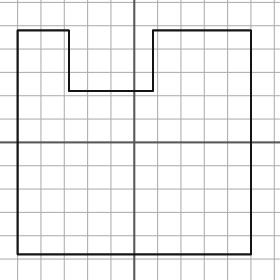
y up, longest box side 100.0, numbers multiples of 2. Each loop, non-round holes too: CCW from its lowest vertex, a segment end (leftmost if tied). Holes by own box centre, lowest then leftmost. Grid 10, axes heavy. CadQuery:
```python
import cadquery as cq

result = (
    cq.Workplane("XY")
    .moveTo(-50.0, -48.0)
    .lineTo(50.0, -48.0)
    .lineTo(50.0, 48.0)
    .lineTo(8.0, 48.0)
    .lineTo(8.0, 22.0)
    .lineTo(-28.0, 22.0)
    .lineTo(-28.0, 48.0)
    .lineTo(-50.0, 48.0)
    .close()
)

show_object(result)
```